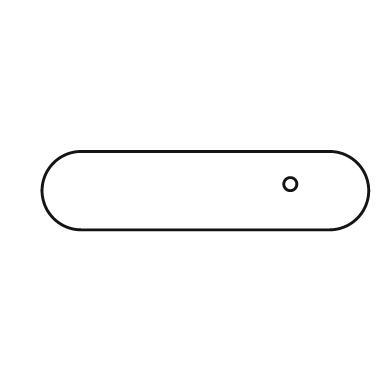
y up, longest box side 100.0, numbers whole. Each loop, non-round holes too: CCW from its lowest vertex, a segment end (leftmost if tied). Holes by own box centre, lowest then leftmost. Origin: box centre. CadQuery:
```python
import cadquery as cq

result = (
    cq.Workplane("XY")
    .moveTo(-38.0, -12.0)
    .lineTo(38.0, -12.0)
    .threePointArc((50.0, 0.0), (38.0, 12.0))
    .lineTo(-38.0, 12.0)
    .threePointArc((-50.0, 0.0), (-38.0, -12.0))
    .close()
    .moveTo(26.0, 2.0)
    .circle(2.0)
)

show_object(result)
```